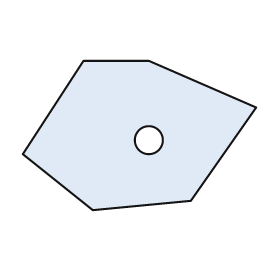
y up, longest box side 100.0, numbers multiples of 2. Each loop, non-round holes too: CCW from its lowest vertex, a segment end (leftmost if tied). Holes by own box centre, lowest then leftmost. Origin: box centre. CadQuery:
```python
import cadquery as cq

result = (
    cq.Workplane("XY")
    .moveTo(-20.0, -32.0)
    .lineTo(22.0, -28.0)
    .lineTo(50.0, 12.0)
    .lineTo(4.0, 32.0)
    .lineTo(-24.0, 32.0)
    .lineTo(-50.0, -8.0)
    .close()
    .moveTo(4.0, -2.0)
    .circle(6.0)
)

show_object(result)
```